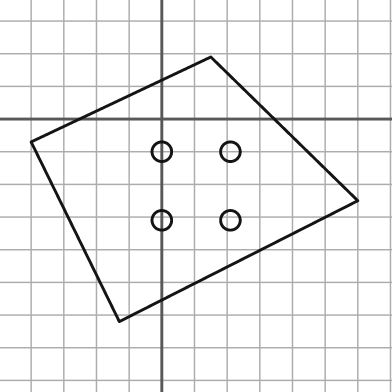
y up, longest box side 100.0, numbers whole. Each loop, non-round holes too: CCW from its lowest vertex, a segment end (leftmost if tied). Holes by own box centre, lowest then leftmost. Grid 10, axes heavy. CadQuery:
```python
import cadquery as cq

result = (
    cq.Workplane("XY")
    .moveTo(-13.0, -62.0)
    .lineTo(60.0, -25.0)
    .lineTo(15.0, 19.0)
    .lineTo(-40.0, -7.0)
    .close()
    .moveTo(0.0, -31.0)
    .circle(3.0)
    .moveTo(21.0, -31.0)
    .circle(3.0)
    .moveTo(0.0, -10.0)
    .circle(3.0)
    .moveTo(21.0, -10.0)
    .circle(3.0)
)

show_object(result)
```